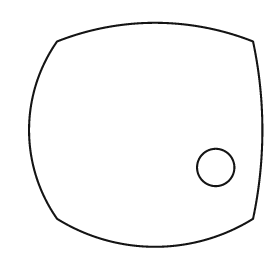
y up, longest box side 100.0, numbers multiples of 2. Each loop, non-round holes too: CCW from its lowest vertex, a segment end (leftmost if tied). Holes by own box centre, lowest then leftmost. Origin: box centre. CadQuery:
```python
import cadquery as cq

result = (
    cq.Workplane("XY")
    .moveTo(-38.0, -36.0)
    .threePointArc((4.0, -48.0), (46.0, -36.0))
    .threePointArc((50.0, 2.0), (46.0, 40.0))
    .threePointArc((4.0, 48.0), (-38.0, 40.0))
    .threePointArc((-50.0, 2.0), (-38.0, -36.0))
    .close()
    .moveTo(30.0, -14.0)
    .circle(8.0)
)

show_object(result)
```